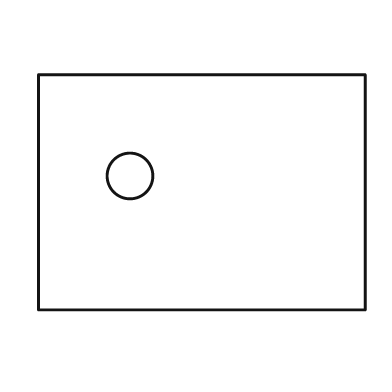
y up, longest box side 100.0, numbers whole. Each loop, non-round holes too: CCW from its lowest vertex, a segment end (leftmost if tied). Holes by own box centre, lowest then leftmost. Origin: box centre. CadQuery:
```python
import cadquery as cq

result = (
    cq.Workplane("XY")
    .moveTo(-50.0, -36.0)
    .lineTo(50.0, -36.0)
    .lineTo(50.0, 36.0)
    .lineTo(-50.0, 36.0)
    .close()
    .moveTo(-22.0, 5.0)
    .circle(7.0)
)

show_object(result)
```